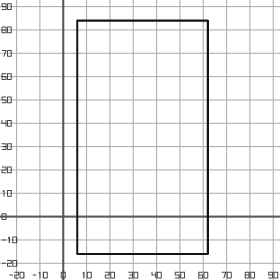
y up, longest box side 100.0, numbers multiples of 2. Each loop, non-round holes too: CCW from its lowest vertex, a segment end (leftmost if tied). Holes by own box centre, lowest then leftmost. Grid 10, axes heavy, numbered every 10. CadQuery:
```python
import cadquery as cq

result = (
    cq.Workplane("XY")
    .moveTo(6.0, -16.0)
    .lineTo(62.0, -16.0)
    .lineTo(62.0, 84.0)
    .lineTo(6.0, 84.0)
    .close()
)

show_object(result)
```